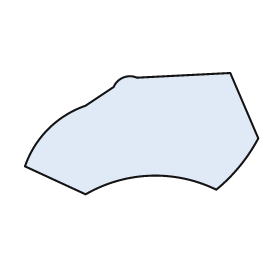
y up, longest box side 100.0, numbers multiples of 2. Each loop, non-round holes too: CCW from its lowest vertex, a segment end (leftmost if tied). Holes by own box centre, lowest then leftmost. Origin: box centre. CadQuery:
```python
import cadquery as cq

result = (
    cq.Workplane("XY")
    .moveTo(-24.0, -26.0)
    .threePointArc((4.0, -18.0), (32.0, -24.0))
    .threePointArc((42.0, -14.0), (50.0, -2.0))
    .lineTo(38.0, 26.0)
    .lineTo(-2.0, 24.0)
    .threePointArc((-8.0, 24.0), (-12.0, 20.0))
    .lineTo(-24.0, 12.0)
    .threePointArc((-40.0, 2.0), (-50.0, -14.0))
    .close()
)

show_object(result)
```